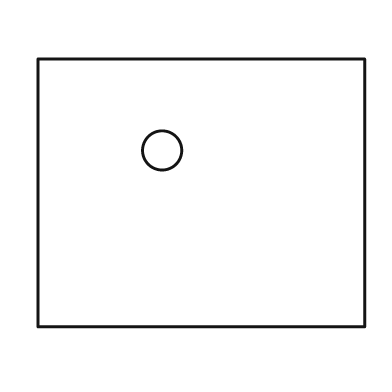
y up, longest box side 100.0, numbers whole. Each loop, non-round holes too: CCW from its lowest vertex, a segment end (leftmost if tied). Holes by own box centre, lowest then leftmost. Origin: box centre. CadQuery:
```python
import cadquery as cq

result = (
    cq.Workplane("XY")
    .moveTo(-50.0, -41.0)
    .lineTo(50.0, -41.0)
    .lineTo(50.0, 41.0)
    .lineTo(-50.0, 41.0)
    .close()
    .moveTo(-12.0, 13.0)
    .circle(6.0)
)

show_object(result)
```